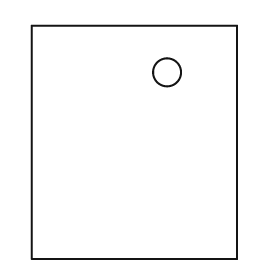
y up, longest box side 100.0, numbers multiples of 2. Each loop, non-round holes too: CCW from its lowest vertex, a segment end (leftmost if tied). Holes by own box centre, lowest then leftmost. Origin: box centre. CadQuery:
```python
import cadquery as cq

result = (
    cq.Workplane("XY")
    .moveTo(-44.0, -50.0)
    .lineTo(44.0, -50.0)
    .lineTo(44.0, 50.0)
    .lineTo(-44.0, 50.0)
    .close()
    .moveTo(14.0, 30.0)
    .circle(6.0)
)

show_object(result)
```